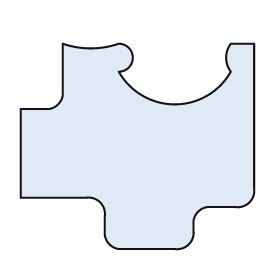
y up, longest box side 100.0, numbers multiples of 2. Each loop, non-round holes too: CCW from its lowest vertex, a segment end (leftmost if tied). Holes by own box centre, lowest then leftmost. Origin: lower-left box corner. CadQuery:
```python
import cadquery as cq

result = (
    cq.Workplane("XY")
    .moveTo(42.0, 0.0)
    .lineTo(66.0, 0.0)
    .threePointArc((72.0, 2.0), (74.0, 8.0))
    .lineTo(74.0, 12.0)
    .threePointArc((76.0, 16.0), (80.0, 18.0))
    .lineTo(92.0, 18.0)
    .threePointArc((98.0, 20.0), (100.0, 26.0))
    .lineTo(100.0, 88.0)
    .lineTo(90.0, 88.0)
    .threePointArc((88.0, 82.0), (90.0, 76.0))
    .threePointArc((66.0, 62.0), (42.0, 76.0))
    .threePointArc((48.0, 82.0), (42.0, 88.0))
    .threePointArc((30.0, 86.0), (18.0, 88.0))
    .lineTo(18.0, 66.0)
    .threePointArc((16.0, 62.0), (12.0, 60.0))
    .lineTo(0.0, 60.0)
    .lineTo(0.0, 22.0)
    .lineTo(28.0, 22.0)
    .threePointArc((34.0, 20.0), (36.0, 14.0))
    .lineTo(36.0, 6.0)
    .threePointArc((38.0, 2.0), (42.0, 0.0))
    .close()
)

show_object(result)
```